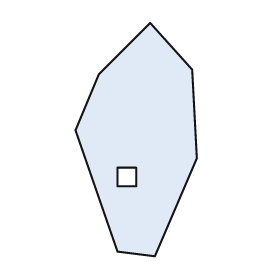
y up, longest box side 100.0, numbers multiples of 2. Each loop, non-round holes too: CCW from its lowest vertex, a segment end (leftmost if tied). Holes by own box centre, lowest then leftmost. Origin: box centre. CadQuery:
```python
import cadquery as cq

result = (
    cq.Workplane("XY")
    .moveTo(8.0, -50.0)
    .lineTo(26.0, -8.0)
    .lineTo(24.0, 30.0)
    .lineTo(6.0, 50.0)
    .lineTo(-16.0, 28.0)
    .lineTo(-26.0, 4.0)
    .lineTo(-8.0, -48.0)
    .close()
    .moveTo(-8.0, -20.0)
    .lineTo(0.0, -20.0)
    .lineTo(0.0, -12.0)
    .lineTo(-8.0, -12.0)
    .close()
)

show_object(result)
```